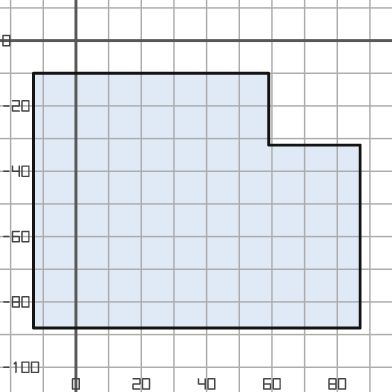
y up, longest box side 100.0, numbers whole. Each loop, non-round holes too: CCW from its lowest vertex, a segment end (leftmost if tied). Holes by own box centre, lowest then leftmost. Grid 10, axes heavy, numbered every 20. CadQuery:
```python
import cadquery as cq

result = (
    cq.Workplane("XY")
    .moveTo(-13.0, -88.0)
    .lineTo(87.0, -88.0)
    .lineTo(87.0, -32.0)
    .lineTo(59.0, -32.0)
    .lineTo(59.0, -10.0)
    .lineTo(-13.0, -10.0)
    .close()
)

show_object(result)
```